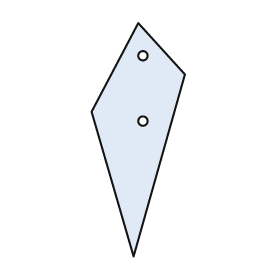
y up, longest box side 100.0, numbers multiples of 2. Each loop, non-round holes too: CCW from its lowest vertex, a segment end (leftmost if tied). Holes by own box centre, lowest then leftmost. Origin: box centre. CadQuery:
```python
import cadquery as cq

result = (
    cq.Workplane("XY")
    .moveTo(-2.0, -50.0)
    .lineTo(20.0, 28.0)
    .lineTo(0.0, 50.0)
    .lineTo(-20.0, 12.0)
    .close()
    .moveTo(2.0, 8.0)
    .circle(2.0)
    .moveTo(2.0, 36.0)
    .circle(2.0)
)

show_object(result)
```